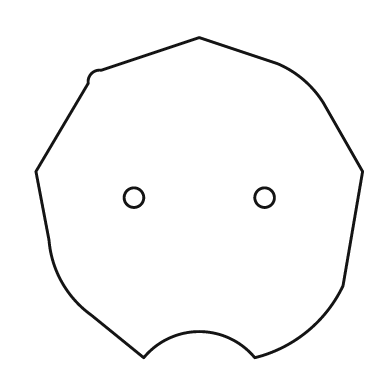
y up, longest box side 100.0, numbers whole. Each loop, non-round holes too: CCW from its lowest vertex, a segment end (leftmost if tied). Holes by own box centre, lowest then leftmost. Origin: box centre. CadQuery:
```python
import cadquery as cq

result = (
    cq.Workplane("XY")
    .moveTo(-17.0, -49.0)
    .threePointArc((0.0, -41.0), (17.0, -49.0))
    .threePointArc((33.0, -41.0), (44.0, -27.0))
    .lineTo(50.0, 8.0)
    .lineTo(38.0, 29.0)
    .threePointArc((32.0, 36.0), (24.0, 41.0))
    .lineTo(0.0, 49.0)
    .lineTo(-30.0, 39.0)
    .threePointArc((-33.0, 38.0), (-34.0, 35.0))
    .lineTo(-50.0, 8.0)
    .lineTo(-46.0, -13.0)
    .threePointArc((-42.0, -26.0), (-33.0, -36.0))
    .close()
    .moveTo(-20.0, 0.0)
    .circle(3.0)
    .moveTo(20.0, 0.0)
    .circle(3.0)
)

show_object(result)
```